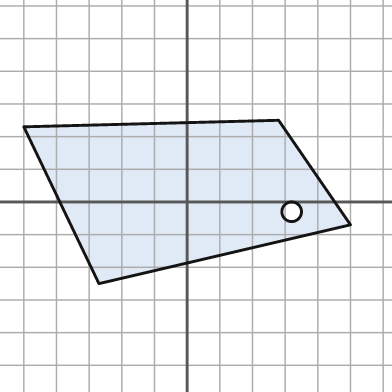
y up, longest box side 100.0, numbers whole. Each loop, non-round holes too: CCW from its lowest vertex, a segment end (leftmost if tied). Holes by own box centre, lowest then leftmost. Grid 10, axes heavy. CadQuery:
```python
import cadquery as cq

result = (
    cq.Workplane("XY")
    .moveTo(-27.0, -25.0)
    .lineTo(50.0, -7.0)
    .lineTo(28.0, 25.0)
    .lineTo(-50.0, 23.0)
    .close()
    .moveTo(32.0, -3.0)
    .circle(3.0)
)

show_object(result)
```